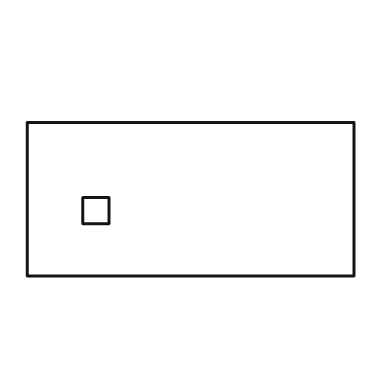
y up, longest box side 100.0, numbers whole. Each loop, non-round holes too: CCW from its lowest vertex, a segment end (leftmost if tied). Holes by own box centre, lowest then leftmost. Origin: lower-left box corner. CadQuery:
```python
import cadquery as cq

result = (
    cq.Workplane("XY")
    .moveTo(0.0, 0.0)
    .lineTo(100.0, 0.0)
    .lineTo(100.0, 47.0)
    .lineTo(0.0, 47.0)
    .close()
    .moveTo(17.0, 16.0)
    .lineTo(25.0, 16.0)
    .lineTo(25.0, 24.0)
    .lineTo(17.0, 24.0)
    .close()
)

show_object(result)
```